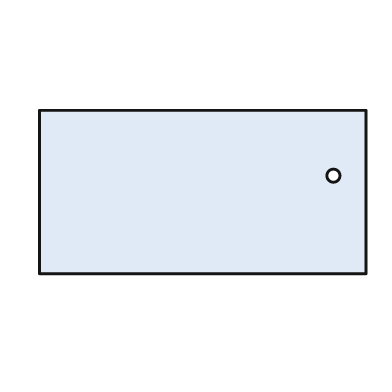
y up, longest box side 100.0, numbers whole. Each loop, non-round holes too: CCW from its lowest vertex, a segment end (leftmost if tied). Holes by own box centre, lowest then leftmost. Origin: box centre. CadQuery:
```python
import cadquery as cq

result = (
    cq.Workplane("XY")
    .moveTo(-50.0, -25.0)
    .lineTo(50.0, -25.0)
    .lineTo(50.0, 25.0)
    .lineTo(-50.0, 25.0)
    .close()
    .moveTo(40.0, 5.0)
    .circle(2.0)
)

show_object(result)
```